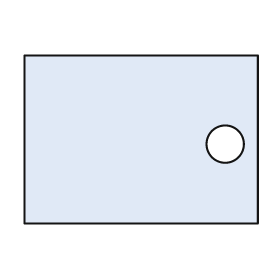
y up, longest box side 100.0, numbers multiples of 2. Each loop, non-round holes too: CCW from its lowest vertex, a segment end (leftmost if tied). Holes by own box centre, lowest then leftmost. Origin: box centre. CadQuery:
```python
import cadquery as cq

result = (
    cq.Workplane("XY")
    .moveTo(-50.0, -36.0)
    .lineTo(50.0, -36.0)
    .lineTo(50.0, 36.0)
    .lineTo(-50.0, 36.0)
    .close()
    .moveTo(36.0, -2.0)
    .circle(8.0)
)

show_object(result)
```